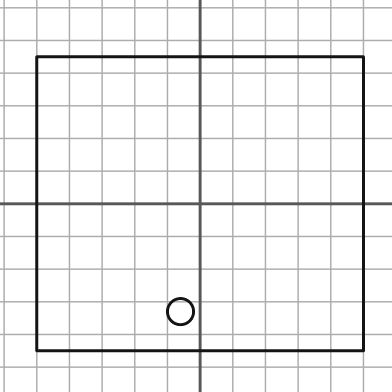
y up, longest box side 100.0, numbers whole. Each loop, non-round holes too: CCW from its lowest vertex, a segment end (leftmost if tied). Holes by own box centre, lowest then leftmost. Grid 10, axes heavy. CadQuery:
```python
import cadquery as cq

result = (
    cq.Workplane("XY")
    .moveTo(-50.0, -45.0)
    .lineTo(50.0, -45.0)
    .lineTo(50.0, 45.0)
    .lineTo(-50.0, 45.0)
    .close()
    .moveTo(-6.0, -33.0)
    .circle(4.0)
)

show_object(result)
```